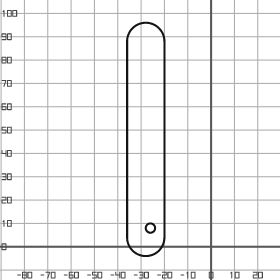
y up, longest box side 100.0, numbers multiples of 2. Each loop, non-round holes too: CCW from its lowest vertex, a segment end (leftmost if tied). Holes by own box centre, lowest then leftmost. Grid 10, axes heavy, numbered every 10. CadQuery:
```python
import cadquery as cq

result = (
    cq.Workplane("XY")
    .moveTo(-36.0, 4.0)
    .threePointArc((-28.0, -4.0), (-20.0, 4.0))
    .lineTo(-20.0, 88.0)
    .threePointArc((-28.0, 96.0), (-36.0, 88.0))
    .close()
    .moveTo(-26.0, 8.0)
    .circle(2.0)
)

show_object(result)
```